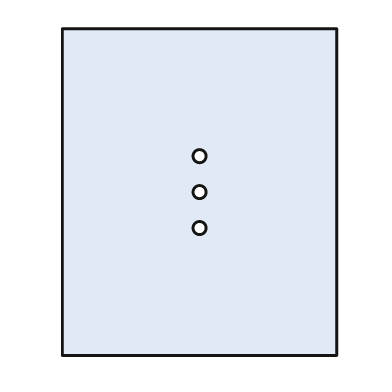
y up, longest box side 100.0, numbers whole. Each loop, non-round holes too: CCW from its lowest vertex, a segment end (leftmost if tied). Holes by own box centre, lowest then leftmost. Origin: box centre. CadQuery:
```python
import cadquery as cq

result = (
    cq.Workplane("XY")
    .moveTo(-42.0, -50.0)
    .lineTo(42.0, -50.0)
    .lineTo(42.0, 50.0)
    .lineTo(-42.0, 50.0)
    .close()
    .moveTo(0.0, -11.0)
    .circle(2.0)
    .moveTo(0.0, 0.0)
    .circle(2.0)
    .moveTo(0.0, 11.0)
    .circle(2.0)
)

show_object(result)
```